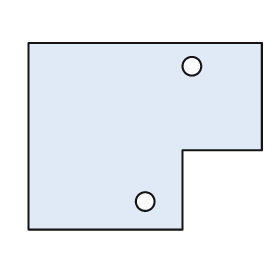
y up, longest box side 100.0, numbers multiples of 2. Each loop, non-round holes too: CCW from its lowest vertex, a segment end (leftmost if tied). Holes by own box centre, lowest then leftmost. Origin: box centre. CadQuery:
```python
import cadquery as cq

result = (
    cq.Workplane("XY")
    .moveTo(-50.0, -40.0)
    .lineTo(16.0, -40.0)
    .lineTo(16.0, -6.0)
    .lineTo(50.0, -6.0)
    .lineTo(50.0, 40.0)
    .lineTo(-50.0, 40.0)
    .close()
    .moveTo(0.0, -28.0)
    .circle(4.0)
    .moveTo(20.0, 30.0)
    .circle(4.0)
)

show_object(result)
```